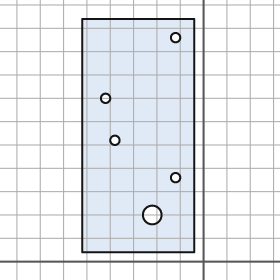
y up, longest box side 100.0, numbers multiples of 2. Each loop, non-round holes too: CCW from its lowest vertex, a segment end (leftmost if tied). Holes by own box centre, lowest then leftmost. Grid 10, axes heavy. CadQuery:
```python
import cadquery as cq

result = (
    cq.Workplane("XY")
    .moveTo(-52.0, 4.0)
    .lineTo(-4.0, 4.0)
    .lineTo(-4.0, 104.0)
    .lineTo(-52.0, 104.0)
    .close()
    .moveTo(-22.0, 20.0)
    .circle(4.0)
    .moveTo(-12.0, 36.0)
    .circle(2.0)
    .moveTo(-38.0, 52.0)
    .circle(2.0)
    .moveTo(-42.0, 70.0)
    .circle(2.0)
    .moveTo(-12.0, 96.0)
    .circle(2.0)
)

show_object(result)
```